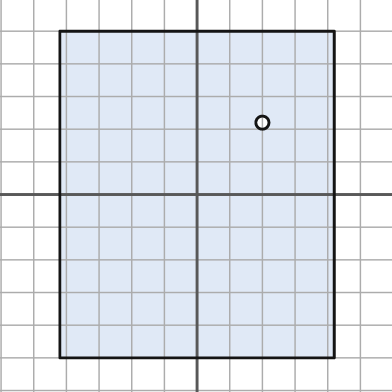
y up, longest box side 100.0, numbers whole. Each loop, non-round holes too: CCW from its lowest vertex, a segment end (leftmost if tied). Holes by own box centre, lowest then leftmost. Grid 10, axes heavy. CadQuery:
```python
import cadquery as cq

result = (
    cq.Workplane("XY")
    .moveTo(-42.0, -50.0)
    .lineTo(42.0, -50.0)
    .lineTo(42.0, 50.0)
    .lineTo(-42.0, 50.0)
    .close()
    .moveTo(20.0, 22.0)
    .circle(2.0)
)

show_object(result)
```